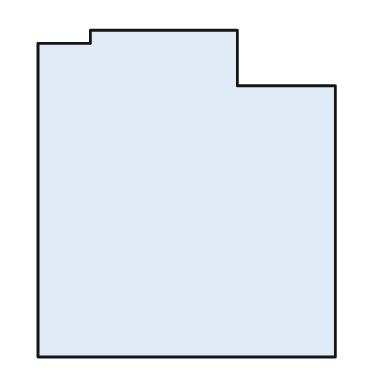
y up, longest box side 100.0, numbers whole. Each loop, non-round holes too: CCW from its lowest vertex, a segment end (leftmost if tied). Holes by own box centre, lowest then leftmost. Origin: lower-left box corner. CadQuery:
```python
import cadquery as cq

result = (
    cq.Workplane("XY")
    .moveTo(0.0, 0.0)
    .lineTo(91.0, 0.0)
    .lineTo(91.0, 83.0)
    .lineTo(61.0, 83.0)
    .lineTo(61.0, 100.0)
    .lineTo(16.0, 100.0)
    .lineTo(16.0, 96.0)
    .lineTo(0.0, 96.0)
    .close()
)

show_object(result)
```